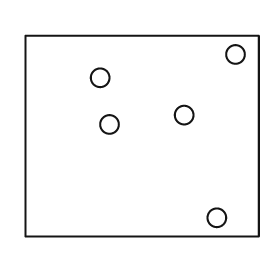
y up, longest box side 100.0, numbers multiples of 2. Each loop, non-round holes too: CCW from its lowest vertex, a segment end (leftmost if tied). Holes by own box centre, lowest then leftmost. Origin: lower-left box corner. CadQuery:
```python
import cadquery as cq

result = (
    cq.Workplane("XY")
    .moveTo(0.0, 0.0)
    .lineTo(100.0, 0.0)
    .lineTo(100.0, 86.0)
    .lineTo(0.0, 86.0)
    .close()
    .moveTo(82.0, 8.0)
    .circle(4.0)
    .moveTo(36.0, 48.0)
    .circle(4.0)
    .moveTo(68.0, 52.0)
    .circle(4.0)
    .moveTo(32.0, 68.0)
    .circle(4.0)
    .moveTo(90.0, 78.0)
    .circle(4.0)
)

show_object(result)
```